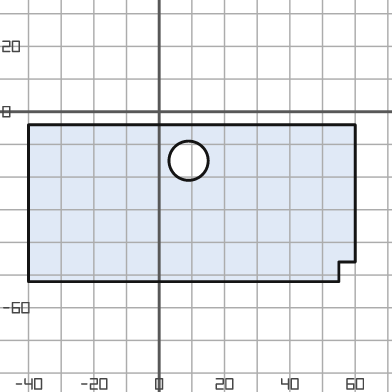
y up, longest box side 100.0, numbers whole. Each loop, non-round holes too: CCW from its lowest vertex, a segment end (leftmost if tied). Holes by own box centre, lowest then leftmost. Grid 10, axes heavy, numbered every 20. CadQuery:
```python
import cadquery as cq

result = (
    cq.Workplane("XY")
    .moveTo(-40.0, -52.0)
    .lineTo(55.0, -52.0)
    .lineTo(55.0, -46.0)
    .lineTo(60.0, -46.0)
    .lineTo(60.0, -4.0)
    .lineTo(-40.0, -4.0)
    .close()
    .moveTo(9.0, -15.0)
    .circle(6.0)
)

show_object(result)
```